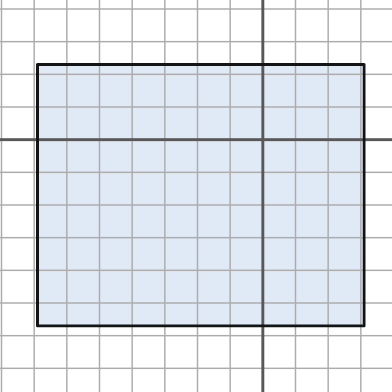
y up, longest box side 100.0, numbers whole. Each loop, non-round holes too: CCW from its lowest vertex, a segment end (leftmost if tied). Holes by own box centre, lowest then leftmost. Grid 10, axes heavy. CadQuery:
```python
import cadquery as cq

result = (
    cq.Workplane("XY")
    .moveTo(-69.0, -57.0)
    .lineTo(31.0, -57.0)
    .lineTo(31.0, 23.0)
    .lineTo(-69.0, 23.0)
    .close()
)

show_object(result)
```